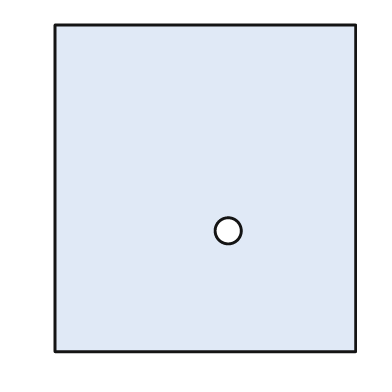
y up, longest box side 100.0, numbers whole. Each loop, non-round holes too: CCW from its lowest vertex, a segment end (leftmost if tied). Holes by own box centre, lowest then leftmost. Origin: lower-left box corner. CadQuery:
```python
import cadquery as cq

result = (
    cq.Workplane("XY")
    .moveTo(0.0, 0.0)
    .lineTo(92.0, 0.0)
    .lineTo(92.0, 100.0)
    .lineTo(0.0, 100.0)
    .close()
    .moveTo(53.0, 37.0)
    .circle(4.0)
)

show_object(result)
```